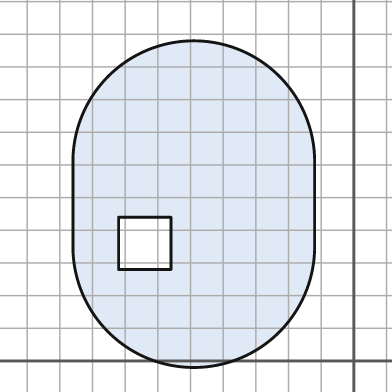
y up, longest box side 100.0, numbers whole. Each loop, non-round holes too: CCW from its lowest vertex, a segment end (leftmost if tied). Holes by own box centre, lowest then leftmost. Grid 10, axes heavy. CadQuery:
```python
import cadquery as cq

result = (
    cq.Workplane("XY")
    .moveTo(-86.0, 35.0)
    .threePointArc((-49.0, -2.0), (-12.0, 35.0))
    .lineTo(-12.0, 61.0)
    .threePointArc((-49.0, 98.0), (-86.0, 61.0))
    .close()
    .moveTo(-72.0, 28.0)
    .lineTo(-56.0, 28.0)
    .lineTo(-56.0, 44.0)
    .lineTo(-72.0, 44.0)
    .close()
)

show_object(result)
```